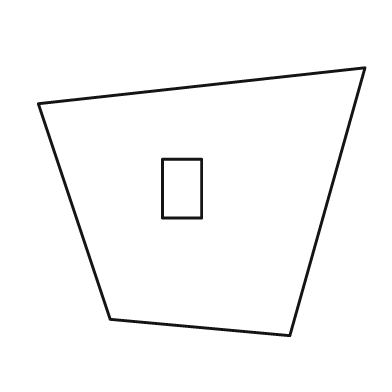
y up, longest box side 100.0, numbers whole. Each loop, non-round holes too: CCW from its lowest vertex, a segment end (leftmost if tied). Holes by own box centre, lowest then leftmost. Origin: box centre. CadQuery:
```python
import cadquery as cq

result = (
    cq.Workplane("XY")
    .moveTo(27.0, -41.0)
    .lineTo(50.0, 41.0)
    .lineTo(-50.0, 30.0)
    .lineTo(-28.0, -36.0)
    .close()
    .moveTo(-12.0, -5.0)
    .lineTo(0.0, -5.0)
    .lineTo(0.0, 13.0)
    .lineTo(-12.0, 13.0)
    .close()
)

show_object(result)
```